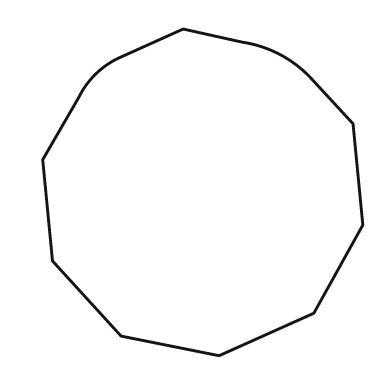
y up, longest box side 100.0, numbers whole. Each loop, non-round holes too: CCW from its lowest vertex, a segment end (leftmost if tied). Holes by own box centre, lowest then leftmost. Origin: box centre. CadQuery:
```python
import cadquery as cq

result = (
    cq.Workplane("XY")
    .moveTo(5.0, -50.0)
    .lineTo(34.0, -37.0)
    .lineTo(49.0, -10.0)
    .lineTo(46.0, 21.0)
    .lineTo(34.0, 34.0)
    .threePointArc((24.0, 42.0), (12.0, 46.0))
    .lineTo(-6.0, 50.0)
    .lineTo(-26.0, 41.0)
    .threePointArc((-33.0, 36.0), (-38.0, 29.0))
    .lineTo(-49.0, 10.0)
    .lineTo(-46.0, -21.0)
    .lineTo(-25.0, -44.0)
    .close()
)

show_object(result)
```